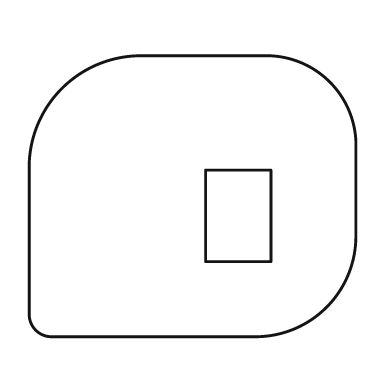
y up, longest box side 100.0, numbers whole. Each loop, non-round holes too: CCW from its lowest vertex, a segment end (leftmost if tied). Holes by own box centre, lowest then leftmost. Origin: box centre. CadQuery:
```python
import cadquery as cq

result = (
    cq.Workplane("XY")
    .moveTo(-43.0, -43.0)
    .lineTo(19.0, -43.0)
    .threePointArc((41.0, -34.0), (50.0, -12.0))
    .lineTo(50.0, 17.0)
    .threePointArc((42.0, 35.0), (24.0, 43.0))
    .lineTo(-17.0, 43.0)
    .threePointArc((-40.0, 33.0), (-50.0, 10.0))
    .lineTo(-50.0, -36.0)
    .threePointArc((-48.0, -41.0), (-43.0, -43.0))
    .close()
    .moveTo(4.0, -20.0)
    .lineTo(24.0, -20.0)
    .lineTo(24.0, 8.0)
    .lineTo(4.0, 8.0)
    .close()
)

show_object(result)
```